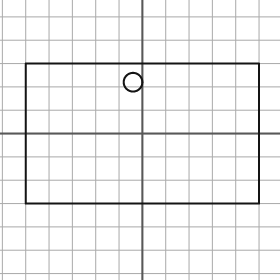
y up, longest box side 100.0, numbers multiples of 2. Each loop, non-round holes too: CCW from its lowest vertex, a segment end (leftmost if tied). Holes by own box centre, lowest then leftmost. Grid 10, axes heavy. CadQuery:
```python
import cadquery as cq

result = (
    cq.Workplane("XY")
    .moveTo(-50.0, -30.0)
    .lineTo(50.0, -30.0)
    .lineTo(50.0, 30.0)
    .lineTo(-50.0, 30.0)
    .close()
    .moveTo(-4.0, 22.0)
    .circle(4.0)
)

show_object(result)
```